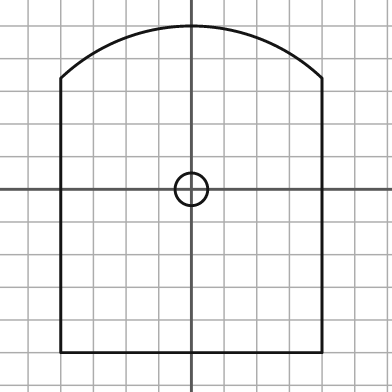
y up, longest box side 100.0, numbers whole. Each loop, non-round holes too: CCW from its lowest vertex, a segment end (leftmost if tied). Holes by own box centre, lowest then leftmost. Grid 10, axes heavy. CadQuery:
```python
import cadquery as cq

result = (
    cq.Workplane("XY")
    .moveTo(-40.0, -50.0)
    .lineTo(40.0, -50.0)
    .lineTo(40.0, 34.0)
    .threePointArc((0.0, 50.0), (-40.0, 34.0))
    .close()
    .moveTo(0.0, 0.0)
    .circle(5.0)
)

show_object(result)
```